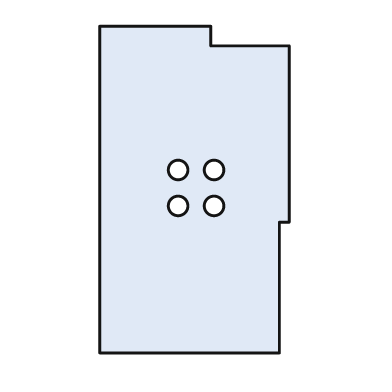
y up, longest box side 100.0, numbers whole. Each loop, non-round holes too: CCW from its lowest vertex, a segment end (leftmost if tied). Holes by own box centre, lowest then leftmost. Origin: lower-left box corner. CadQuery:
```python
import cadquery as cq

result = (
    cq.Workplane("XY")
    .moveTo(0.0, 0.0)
    .lineTo(55.0, 0.0)
    .lineTo(55.0, 40.0)
    .lineTo(58.0, 40.0)
    .lineTo(58.0, 94.0)
    .lineTo(34.0, 94.0)
    .lineTo(34.0, 100.0)
    .lineTo(0.0, 100.0)
    .close()
    .moveTo(24.0, 45.0)
    .circle(3.0)
    .moveTo(35.0, 45.0)
    .circle(3.0)
    .moveTo(24.0, 56.0)
    .circle(3.0)
    .moveTo(35.0, 56.0)
    .circle(3.0)
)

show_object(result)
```